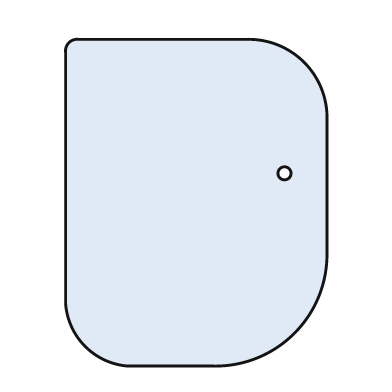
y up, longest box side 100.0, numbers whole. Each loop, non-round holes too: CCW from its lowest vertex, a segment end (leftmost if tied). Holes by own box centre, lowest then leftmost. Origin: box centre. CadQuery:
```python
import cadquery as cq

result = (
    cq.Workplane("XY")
    .moveTo(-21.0, -50.0)
    .lineTo(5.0, -50.0)
    .threePointArc((30.0, -40.0), (40.0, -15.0))
    .lineTo(40.0, 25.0)
    .threePointArc((33.0, 43.0), (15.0, 50.0))
    .lineTo(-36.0, 50.0)
    .threePointArc((-39.0, 49.0), (-40.0, 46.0))
    .lineTo(-40.0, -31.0)
    .threePointArc((-34.0, -44.0), (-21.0, -50.0))
    .close()
    .moveTo(27.0, 9.0)
    .circle(2.0)
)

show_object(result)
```